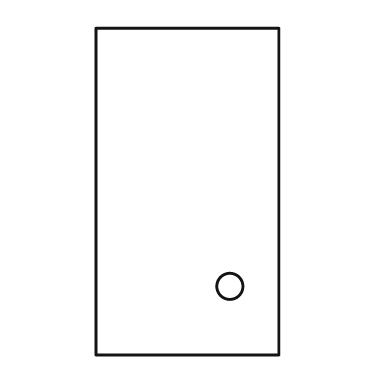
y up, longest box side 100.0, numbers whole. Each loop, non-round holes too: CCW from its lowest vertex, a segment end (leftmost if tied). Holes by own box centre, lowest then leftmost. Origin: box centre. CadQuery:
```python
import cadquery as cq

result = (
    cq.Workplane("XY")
    .moveTo(-28.0, -50.0)
    .lineTo(28.0, -50.0)
    .lineTo(28.0, 50.0)
    .lineTo(-28.0, 50.0)
    .close()
    .moveTo(13.0, -29.0)
    .circle(4.0)
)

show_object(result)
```